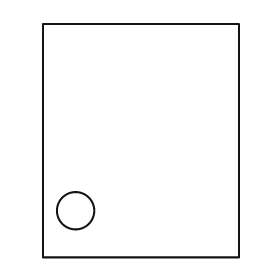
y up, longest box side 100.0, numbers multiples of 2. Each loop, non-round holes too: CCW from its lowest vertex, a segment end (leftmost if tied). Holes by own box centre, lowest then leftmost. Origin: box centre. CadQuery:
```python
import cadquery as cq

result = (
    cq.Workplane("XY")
    .moveTo(-42.0, -50.0)
    .lineTo(42.0, -50.0)
    .lineTo(42.0, 50.0)
    .lineTo(-42.0, 50.0)
    .close()
    .moveTo(-28.0, -30.0)
    .circle(8.0)
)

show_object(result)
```